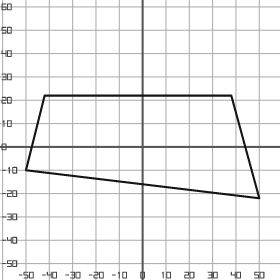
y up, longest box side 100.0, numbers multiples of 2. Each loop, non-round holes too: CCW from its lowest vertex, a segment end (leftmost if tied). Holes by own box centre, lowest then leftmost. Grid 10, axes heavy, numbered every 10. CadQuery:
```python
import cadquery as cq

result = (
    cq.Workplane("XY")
    .moveTo(50.0, -22.0)
    .lineTo(38.0, 22.0)
    .lineTo(-42.0, 22.0)
    .lineTo(-50.0, -10.0)
    .close()
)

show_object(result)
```